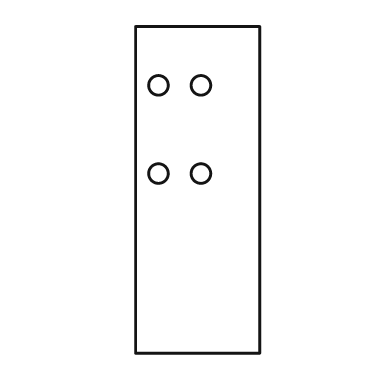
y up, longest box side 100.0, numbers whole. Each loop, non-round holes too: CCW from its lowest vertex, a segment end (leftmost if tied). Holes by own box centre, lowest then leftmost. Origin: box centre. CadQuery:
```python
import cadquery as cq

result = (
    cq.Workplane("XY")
    .moveTo(-19.0, -50.0)
    .lineTo(19.0, -50.0)
    .lineTo(19.0, 50.0)
    .lineTo(-19.0, 50.0)
    .close()
    .moveTo(-12.0, 5.0)
    .circle(3.0)
    .moveTo(1.0, 5.0)
    .circle(3.0)
    .moveTo(-12.0, 32.0)
    .circle(3.0)
    .moveTo(1.0, 32.0)
    .circle(3.0)
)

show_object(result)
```